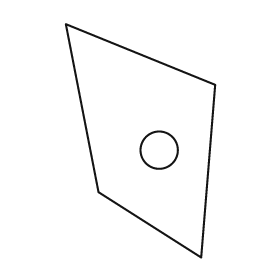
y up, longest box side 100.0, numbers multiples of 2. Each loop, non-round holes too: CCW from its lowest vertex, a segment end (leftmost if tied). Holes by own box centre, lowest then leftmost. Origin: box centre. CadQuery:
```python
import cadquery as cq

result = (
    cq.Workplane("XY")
    .moveTo(26.0, -50.0)
    .lineTo(32.0, 24.0)
    .lineTo(-32.0, 50.0)
    .lineTo(-18.0, -22.0)
    .close()
    .moveTo(8.0, -4.0)
    .circle(8.0)
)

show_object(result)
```